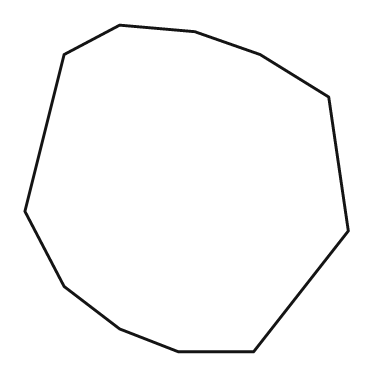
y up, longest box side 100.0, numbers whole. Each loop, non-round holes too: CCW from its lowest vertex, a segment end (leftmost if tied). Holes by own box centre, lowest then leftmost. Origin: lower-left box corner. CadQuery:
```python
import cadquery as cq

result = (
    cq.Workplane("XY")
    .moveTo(47.0, 0.0)
    .lineTo(70.0, 0.0)
    .lineTo(99.0, 37.0)
    .lineTo(93.0, 78.0)
    .lineTo(72.0, 91.0)
    .lineTo(52.0, 98.0)
    .lineTo(29.0, 100.0)
    .lineTo(12.0, 91.0)
    .lineTo(0.0, 43.0)
    .lineTo(12.0, 20.0)
    .lineTo(29.0, 7.0)
    .close()
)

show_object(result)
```